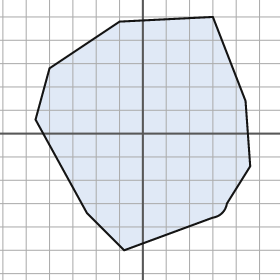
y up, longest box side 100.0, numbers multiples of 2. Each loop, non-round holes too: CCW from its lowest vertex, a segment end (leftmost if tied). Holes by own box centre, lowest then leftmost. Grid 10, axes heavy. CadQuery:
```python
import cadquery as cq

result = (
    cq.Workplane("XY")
    .moveTo(-8.0, -50.0)
    .lineTo(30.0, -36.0)
    .threePointArc((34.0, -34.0), (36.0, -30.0))
    .lineTo(46.0, -14.0)
    .lineTo(44.0, 14.0)
    .lineTo(30.0, 50.0)
    .lineTo(-10.0, 48.0)
    .lineTo(-40.0, 28.0)
    .lineTo(-46.0, 6.0)
    .lineTo(-24.0, -34.0)
    .close()
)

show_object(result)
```